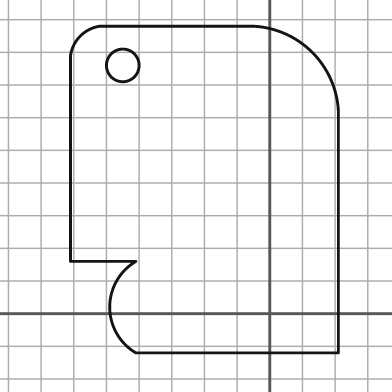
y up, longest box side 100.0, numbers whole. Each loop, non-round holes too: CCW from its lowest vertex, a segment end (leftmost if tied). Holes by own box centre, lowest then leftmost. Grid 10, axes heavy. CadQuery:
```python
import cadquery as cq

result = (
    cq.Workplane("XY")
    .moveTo(-41.0, -12.0)
    .lineTo(21.0, -12.0)
    .lineTo(21.0, 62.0)
    .threePointArc((13.0, 80.0), (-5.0, 88.0))
    .lineTo(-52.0, 88.0)
    .threePointArc((-58.0, 85.0), (-61.0, 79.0))
    .lineTo(-61.0, 16.0)
    .lineTo(-41.0, 16.0)
    .threePointArc((-49.0, 2.0), (-41.0, -12.0))
    .close()
    .moveTo(-45.0, 76.0)
    .circle(5.0)
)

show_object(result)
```